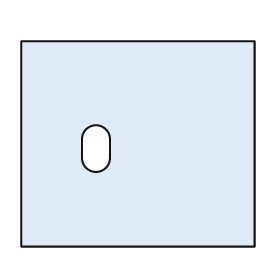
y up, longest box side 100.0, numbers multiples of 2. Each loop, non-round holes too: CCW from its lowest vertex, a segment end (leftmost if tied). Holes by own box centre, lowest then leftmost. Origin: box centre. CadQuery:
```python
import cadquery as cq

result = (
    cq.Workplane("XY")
    .moveTo(-50.0, -44.0)
    .lineTo(50.0, -44.0)
    .lineTo(50.0, 44.0)
    .lineTo(-50.0, 44.0)
    .close()
    .moveTo(-24.0, -6.0)
    .threePointArc((-18.0, -12.0), (-12.0, -6.0))
    .lineTo(-12.0, 2.0)
    .threePointArc((-18.0, 8.0), (-24.0, 2.0))
    .close()
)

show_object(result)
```